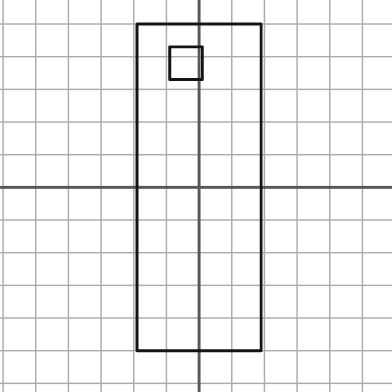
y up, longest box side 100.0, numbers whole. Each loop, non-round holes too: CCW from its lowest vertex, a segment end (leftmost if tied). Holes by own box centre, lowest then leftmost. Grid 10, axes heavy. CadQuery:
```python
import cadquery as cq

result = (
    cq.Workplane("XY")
    .moveTo(-19.0, -50.0)
    .lineTo(19.0, -50.0)
    .lineTo(19.0, 50.0)
    .lineTo(-19.0, 50.0)
    .close()
    .moveTo(-9.0, 33.0)
    .lineTo(1.0, 33.0)
    .lineTo(1.0, 43.0)
    .lineTo(-9.0, 43.0)
    .close()
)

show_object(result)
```